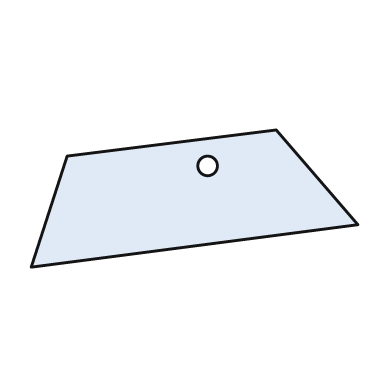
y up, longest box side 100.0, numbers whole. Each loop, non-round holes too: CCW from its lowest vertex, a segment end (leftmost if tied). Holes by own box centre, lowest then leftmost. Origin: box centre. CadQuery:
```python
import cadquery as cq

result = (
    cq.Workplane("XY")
    .moveTo(-50.0, -21.0)
    .lineTo(50.0, -8.0)
    .lineTo(25.0, 21.0)
    .lineTo(-39.0, 13.0)
    .close()
    .moveTo(4.0, 10.0)
    .circle(3.0)
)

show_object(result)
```